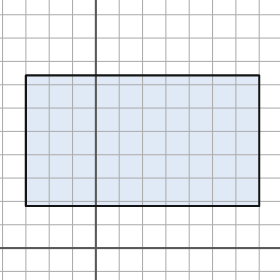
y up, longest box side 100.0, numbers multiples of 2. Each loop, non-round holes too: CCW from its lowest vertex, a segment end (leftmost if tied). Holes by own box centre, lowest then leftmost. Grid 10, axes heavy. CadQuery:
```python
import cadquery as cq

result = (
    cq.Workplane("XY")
    .moveTo(-30.0, 18.0)
    .lineTo(70.0, 18.0)
    .lineTo(70.0, 74.0)
    .lineTo(-30.0, 74.0)
    .close()
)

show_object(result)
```